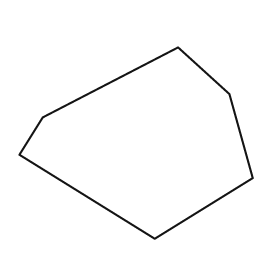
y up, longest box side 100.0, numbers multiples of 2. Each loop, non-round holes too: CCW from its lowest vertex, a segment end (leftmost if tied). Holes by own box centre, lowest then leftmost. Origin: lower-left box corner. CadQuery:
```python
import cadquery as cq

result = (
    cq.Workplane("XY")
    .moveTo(58.0, 0.0)
    .lineTo(100.0, 26.0)
    .lineTo(90.0, 62.0)
    .lineTo(68.0, 82.0)
    .lineTo(10.0, 52.0)
    .lineTo(0.0, 36.0)
    .close()
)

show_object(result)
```